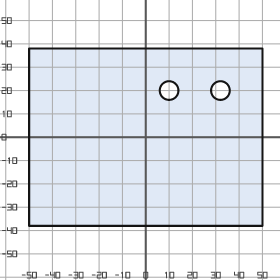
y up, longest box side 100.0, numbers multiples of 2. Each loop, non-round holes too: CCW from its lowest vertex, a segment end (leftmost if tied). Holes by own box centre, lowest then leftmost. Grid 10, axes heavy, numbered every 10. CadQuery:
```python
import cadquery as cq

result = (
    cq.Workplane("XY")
    .moveTo(-50.0, -38.0)
    .lineTo(50.0, -38.0)
    .lineTo(50.0, 38.0)
    .lineTo(-50.0, 38.0)
    .close()
    .moveTo(10.0, 20.0)
    .circle(4.0)
    .moveTo(32.0, 20.0)
    .circle(4.0)
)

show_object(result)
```